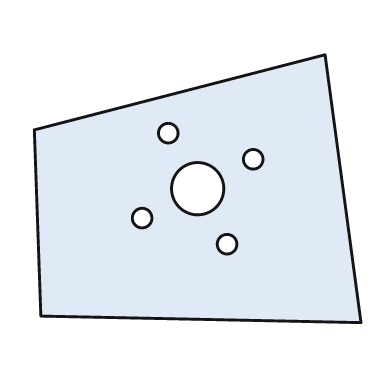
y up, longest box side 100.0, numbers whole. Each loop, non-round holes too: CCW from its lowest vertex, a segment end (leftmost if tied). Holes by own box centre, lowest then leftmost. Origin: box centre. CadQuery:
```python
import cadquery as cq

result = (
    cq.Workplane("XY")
    .moveTo(50.0, -41.0)
    .lineTo(39.0, 41.0)
    .lineTo(-50.0, 18.0)
    .lineTo(-48.0, -39.0)
    .close()
    .moveTo(9.0, -17.0)
    .circle(3.0)
    .moveTo(-17.0, -9.0)
    .circle(3.0)
    .moveTo(0.0, 0.0)
    .circle(8.0)
    .moveTo(17.0, 9.0)
    .circle(3.0)
    .moveTo(-9.0, 17.0)
    .circle(3.0)
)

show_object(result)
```